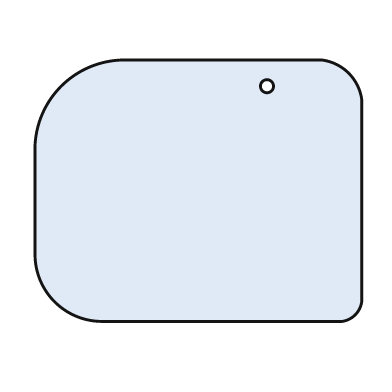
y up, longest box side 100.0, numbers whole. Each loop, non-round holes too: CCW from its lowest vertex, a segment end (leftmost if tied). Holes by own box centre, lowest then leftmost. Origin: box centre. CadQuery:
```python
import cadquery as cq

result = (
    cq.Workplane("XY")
    .moveTo(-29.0, -40.0)
    .lineTo(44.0, -40.0)
    .threePointArc((48.0, -38.0), (50.0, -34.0))
    .lineTo(50.0, 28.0)
    .threePointArc((46.0, 36.0), (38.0, 40.0))
    .lineTo(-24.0, 40.0)
    .threePointArc((-42.0, 32.0), (-50.0, 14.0))
    .lineTo(-50.0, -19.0)
    .threePointArc((-44.0, -34.0), (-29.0, -40.0))
    .close()
    .moveTo(21.0, 32.0)
    .circle(2.0)
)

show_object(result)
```